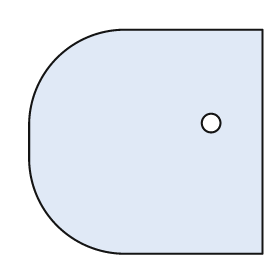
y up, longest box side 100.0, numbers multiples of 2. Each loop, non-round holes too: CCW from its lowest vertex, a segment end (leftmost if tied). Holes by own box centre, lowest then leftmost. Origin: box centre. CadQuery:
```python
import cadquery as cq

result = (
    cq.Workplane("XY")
    .moveTo(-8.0, -48.0)
    .lineTo(50.0, -48.0)
    .lineTo(50.0, 48.0)
    .lineTo(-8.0, 48.0)
    .threePointArc((-38.0, 36.0), (-50.0, 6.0))
    .lineTo(-50.0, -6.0)
    .threePointArc((-38.0, -36.0), (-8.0, -48.0))
    .close()
    .moveTo(28.0, 8.0)
    .circle(4.0)
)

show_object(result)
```